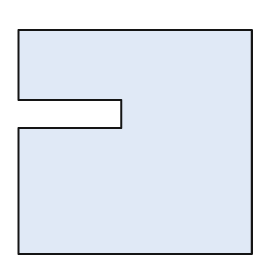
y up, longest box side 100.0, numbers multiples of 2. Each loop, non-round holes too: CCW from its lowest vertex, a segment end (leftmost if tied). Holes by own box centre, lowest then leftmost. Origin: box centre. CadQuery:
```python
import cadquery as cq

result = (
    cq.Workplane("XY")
    .moveTo(-50.0, -48.0)
    .lineTo(50.0, -48.0)
    .lineTo(50.0, 48.0)
    .lineTo(-50.0, 48.0)
    .lineTo(-50.0, 18.0)
    .lineTo(-6.0, 18.0)
    .lineTo(-6.0, 6.0)
    .lineTo(-50.0, 6.0)
    .close()
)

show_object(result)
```